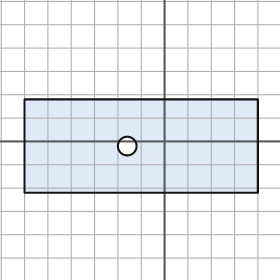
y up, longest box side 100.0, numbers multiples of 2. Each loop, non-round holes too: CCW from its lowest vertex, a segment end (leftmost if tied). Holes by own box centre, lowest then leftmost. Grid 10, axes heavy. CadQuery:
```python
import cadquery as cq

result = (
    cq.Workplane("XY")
    .moveTo(-60.0, -22.0)
    .lineTo(40.0, -22.0)
    .lineTo(40.0, 18.0)
    .lineTo(-60.0, 18.0)
    .close()
    .moveTo(-16.0, -2.0)
    .circle(4.0)
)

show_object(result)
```